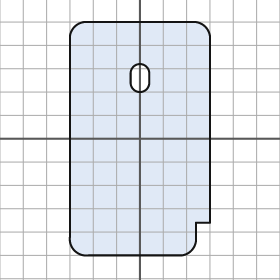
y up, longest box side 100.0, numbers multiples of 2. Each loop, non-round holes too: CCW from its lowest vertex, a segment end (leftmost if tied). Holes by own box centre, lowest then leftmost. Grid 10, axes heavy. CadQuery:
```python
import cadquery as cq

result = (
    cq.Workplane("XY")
    .moveTo(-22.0, -50.0)
    .lineTo(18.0, -50.0)
    .threePointArc((22.0, -48.0), (24.0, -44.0))
    .lineTo(24.0, -36.0)
    .lineTo(30.0, -36.0)
    .lineTo(30.0, 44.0)
    .threePointArc((28.0, 48.0), (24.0, 50.0))
    .lineTo(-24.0, 50.0)
    .threePointArc((-28.0, 48.0), (-30.0, 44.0))
    .lineTo(-30.0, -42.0)
    .threePointArc((-28.0, -48.0), (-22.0, -50.0))
    .close()
    .moveTo(-4.0, 24.0)
    .threePointArc((0.0, 20.0), (4.0, 24.0))
    .lineTo(4.0, 28.0)
    .threePointArc((0.0, 32.0), (-4.0, 28.0))
    .close()
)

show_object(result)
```